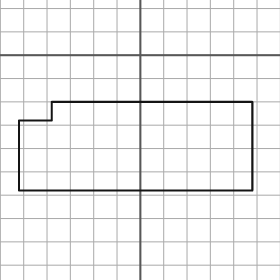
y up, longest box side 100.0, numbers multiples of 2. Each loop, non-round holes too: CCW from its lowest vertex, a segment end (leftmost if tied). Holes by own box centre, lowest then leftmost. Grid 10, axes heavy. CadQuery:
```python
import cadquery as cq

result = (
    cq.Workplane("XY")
    .moveTo(-52.0, -58.0)
    .lineTo(48.0, -58.0)
    .lineTo(48.0, -20.0)
    .lineTo(-38.0, -20.0)
    .lineTo(-38.0, -28.0)
    .lineTo(-52.0, -28.0)
    .close()
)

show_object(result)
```